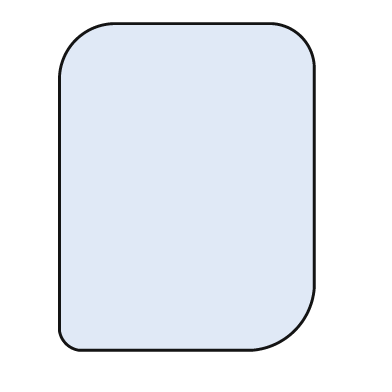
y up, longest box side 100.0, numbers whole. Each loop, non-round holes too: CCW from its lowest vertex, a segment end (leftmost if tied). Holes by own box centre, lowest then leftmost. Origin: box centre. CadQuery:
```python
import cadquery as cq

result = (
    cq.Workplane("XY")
    .moveTo(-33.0, -50.0)
    .lineTo(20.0, -50.0)
    .threePointArc((33.0, -44.0), (39.0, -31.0))
    .lineTo(39.0, 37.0)
    .threePointArc((35.0, 46.0), (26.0, 50.0))
    .lineTo(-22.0, 50.0)
    .threePointArc((-34.0, 45.0), (-39.0, 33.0))
    .lineTo(-39.0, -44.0)
    .threePointArc((-37.0, -48.0), (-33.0, -50.0))
    .close()
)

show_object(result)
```